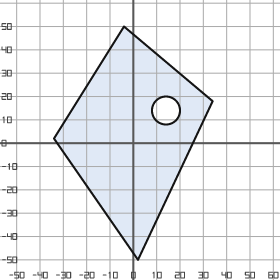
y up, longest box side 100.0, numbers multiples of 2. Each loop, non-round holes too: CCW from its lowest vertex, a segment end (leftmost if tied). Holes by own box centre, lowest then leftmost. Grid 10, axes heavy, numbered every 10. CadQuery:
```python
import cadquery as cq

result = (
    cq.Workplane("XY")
    .moveTo(2.0, -50.0)
    .lineTo(34.0, 18.0)
    .lineTo(-4.0, 50.0)
    .lineTo(-34.0, 2.0)
    .close()
    .moveTo(14.0, 14.0)
    .circle(6.0)
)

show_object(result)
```